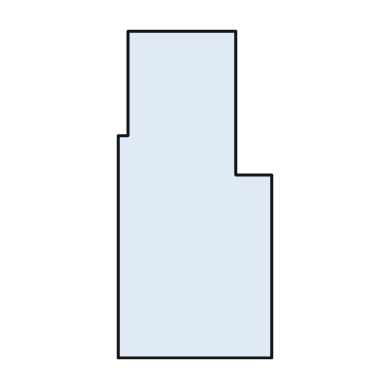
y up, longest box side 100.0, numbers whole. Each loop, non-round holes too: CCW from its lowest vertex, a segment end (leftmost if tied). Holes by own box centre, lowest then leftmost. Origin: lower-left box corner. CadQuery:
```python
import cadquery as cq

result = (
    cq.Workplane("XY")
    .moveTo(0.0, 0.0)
    .lineTo(47.0, 0.0)
    .lineTo(47.0, 56.0)
    .lineTo(36.0, 56.0)
    .lineTo(36.0, 100.0)
    .lineTo(3.0, 100.0)
    .lineTo(3.0, 68.0)
    .lineTo(0.0, 68.0)
    .close()
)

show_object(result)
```